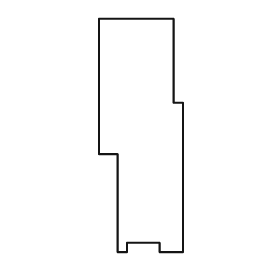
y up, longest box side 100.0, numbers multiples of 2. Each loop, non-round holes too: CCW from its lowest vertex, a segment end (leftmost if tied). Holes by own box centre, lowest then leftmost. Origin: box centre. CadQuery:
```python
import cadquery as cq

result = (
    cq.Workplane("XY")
    .moveTo(-10.0, -50.0)
    .lineTo(-6.0, -50.0)
    .lineTo(-6.0, -46.0)
    .lineTo(8.0, -46.0)
    .lineTo(8.0, -50.0)
    .lineTo(18.0, -50.0)
    .lineTo(18.0, 14.0)
    .lineTo(14.0, 14.0)
    .lineTo(14.0, 50.0)
    .lineTo(-18.0, 50.0)
    .lineTo(-18.0, -8.0)
    .lineTo(-10.0, -8.0)
    .close()
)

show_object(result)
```